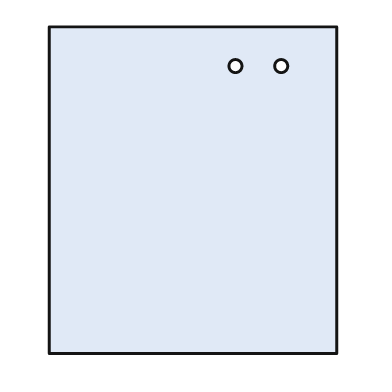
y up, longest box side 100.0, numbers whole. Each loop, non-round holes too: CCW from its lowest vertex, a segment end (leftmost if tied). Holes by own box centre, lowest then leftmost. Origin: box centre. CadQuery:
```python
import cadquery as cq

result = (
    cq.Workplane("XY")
    .moveTo(-44.0, -50.0)
    .lineTo(44.0, -50.0)
    .lineTo(44.0, 50.0)
    .lineTo(-44.0, 50.0)
    .close()
    .moveTo(13.0, 38.0)
    .circle(2.0)
    .moveTo(27.0, 38.0)
    .circle(2.0)
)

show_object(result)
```